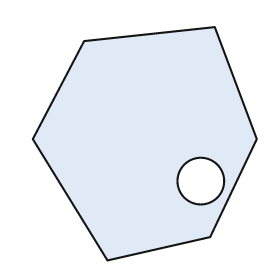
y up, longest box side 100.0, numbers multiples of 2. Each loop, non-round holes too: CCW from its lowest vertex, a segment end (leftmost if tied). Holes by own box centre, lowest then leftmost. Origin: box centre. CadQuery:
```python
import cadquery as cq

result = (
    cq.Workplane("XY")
    .moveTo(-16.0, -50.0)
    .lineTo(28.0, -40.0)
    .lineTo(48.0, 2.0)
    .lineTo(30.0, 50.0)
    .lineTo(-26.0, 44.0)
    .lineTo(-48.0, 2.0)
    .close()
    .moveTo(24.0, -16.0)
    .circle(10.0)
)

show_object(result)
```